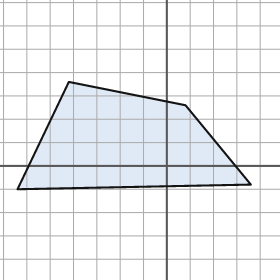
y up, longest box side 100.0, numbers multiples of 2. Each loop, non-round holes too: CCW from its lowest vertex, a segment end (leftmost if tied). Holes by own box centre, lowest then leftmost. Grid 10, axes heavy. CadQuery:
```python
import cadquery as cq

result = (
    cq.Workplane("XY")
    .moveTo(-64.0, -10.0)
    .lineTo(36.0, -8.0)
    .lineTo(8.0, 26.0)
    .lineTo(-42.0, 36.0)
    .close()
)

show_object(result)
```